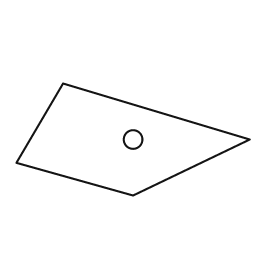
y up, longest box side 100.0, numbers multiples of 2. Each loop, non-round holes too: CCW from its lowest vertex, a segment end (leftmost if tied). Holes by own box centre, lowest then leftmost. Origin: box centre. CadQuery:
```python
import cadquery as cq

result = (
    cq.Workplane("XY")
    .moveTo(0.0, -24.0)
    .lineTo(50.0, 0.0)
    .lineTo(-30.0, 24.0)
    .lineTo(-50.0, -10.0)
    .close()
    .moveTo(0.0, 0.0)
    .circle(4.0)
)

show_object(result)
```